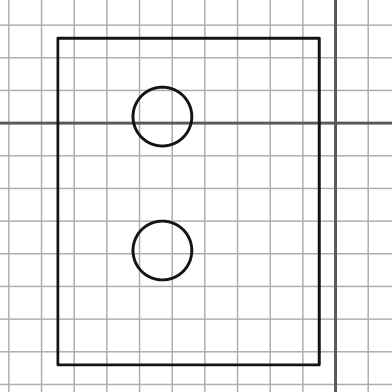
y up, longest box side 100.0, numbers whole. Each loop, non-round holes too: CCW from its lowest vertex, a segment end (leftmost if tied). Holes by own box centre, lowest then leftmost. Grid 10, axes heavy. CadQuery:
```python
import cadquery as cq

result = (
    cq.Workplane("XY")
    .moveTo(-85.0, -74.0)
    .lineTo(-5.0, -74.0)
    .lineTo(-5.0, 26.0)
    .lineTo(-85.0, 26.0)
    .close()
    .moveTo(-53.0, -39.0)
    .circle(9.0)
    .moveTo(-53.0, 2.0)
    .circle(9.0)
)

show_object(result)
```